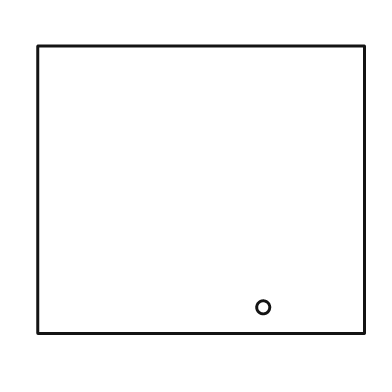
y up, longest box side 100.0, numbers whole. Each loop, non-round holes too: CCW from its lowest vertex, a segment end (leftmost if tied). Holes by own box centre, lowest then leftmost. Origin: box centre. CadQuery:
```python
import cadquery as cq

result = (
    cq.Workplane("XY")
    .moveTo(-50.0, -44.0)
    .lineTo(50.0, -44.0)
    .lineTo(50.0, 44.0)
    .lineTo(-50.0, 44.0)
    .close()
    .moveTo(19.0, -36.0)
    .circle(2.0)
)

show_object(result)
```